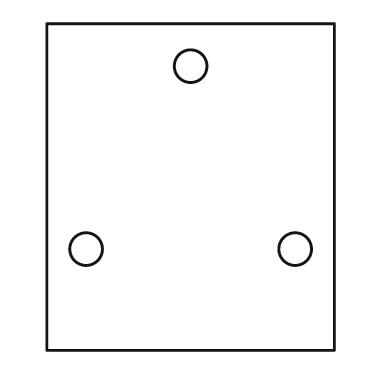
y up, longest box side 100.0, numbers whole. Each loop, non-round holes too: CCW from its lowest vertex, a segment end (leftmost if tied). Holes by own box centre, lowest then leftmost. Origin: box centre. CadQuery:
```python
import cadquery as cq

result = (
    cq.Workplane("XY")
    .moveTo(-44.0, -50.0)
    .lineTo(44.0, -50.0)
    .lineTo(44.0, 50.0)
    .lineTo(-44.0, 50.0)
    .close()
    .moveTo(-32.0, -19.0)
    .circle(5.0)
    .moveTo(32.0, -19.0)
    .circle(5.0)
    .moveTo(0.0, 37.0)
    .circle(5.0)
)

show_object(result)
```